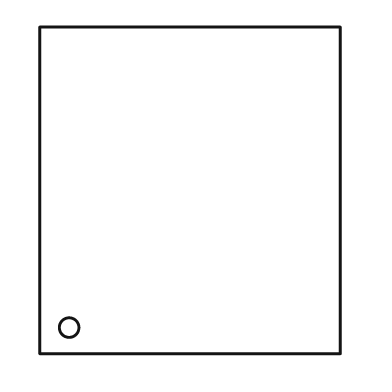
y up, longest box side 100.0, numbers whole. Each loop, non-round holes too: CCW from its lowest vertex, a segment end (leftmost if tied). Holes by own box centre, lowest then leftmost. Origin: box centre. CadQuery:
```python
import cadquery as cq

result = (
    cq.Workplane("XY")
    .moveTo(-46.0, -50.0)
    .lineTo(46.0, -50.0)
    .lineTo(46.0, 50.0)
    .lineTo(-46.0, 50.0)
    .close()
    .moveTo(-37.0, -42.0)
    .circle(3.0)
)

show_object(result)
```